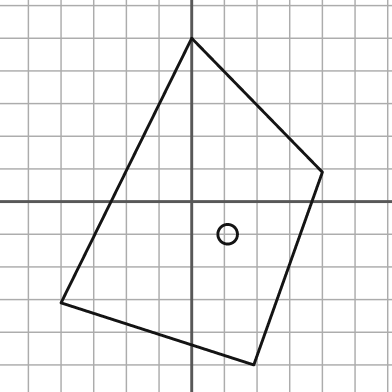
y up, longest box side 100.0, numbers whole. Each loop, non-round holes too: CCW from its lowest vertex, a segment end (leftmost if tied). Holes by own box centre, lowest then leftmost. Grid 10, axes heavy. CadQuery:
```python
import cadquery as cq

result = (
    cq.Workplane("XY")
    .moveTo(19.0, -50.0)
    .lineTo(40.0, 9.0)
    .lineTo(0.0, 50.0)
    .lineTo(-40.0, -31.0)
    .close()
    .moveTo(11.0, -10.0)
    .circle(3.0)
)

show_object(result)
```